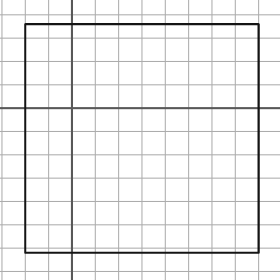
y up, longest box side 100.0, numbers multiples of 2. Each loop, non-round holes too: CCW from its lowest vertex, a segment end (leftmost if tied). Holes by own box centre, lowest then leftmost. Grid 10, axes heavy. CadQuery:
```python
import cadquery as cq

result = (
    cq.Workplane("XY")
    .moveTo(-20.0, -62.0)
    .lineTo(80.0, -62.0)
    .lineTo(80.0, 36.0)
    .lineTo(-20.0, 36.0)
    .close()
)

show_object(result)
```